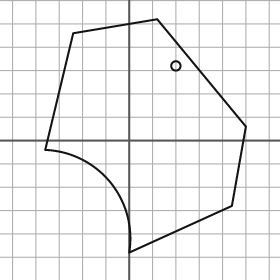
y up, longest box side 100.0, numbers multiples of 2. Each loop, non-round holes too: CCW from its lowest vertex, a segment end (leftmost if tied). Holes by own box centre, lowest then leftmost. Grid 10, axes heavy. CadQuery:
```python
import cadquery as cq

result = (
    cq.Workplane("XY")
    .moveTo(0.0, -48.0)
    .lineTo(44.0, -28.0)
    .lineTo(50.0, 6.0)
    .lineTo(12.0, 52.0)
    .lineTo(-24.0, 46.0)
    .lineTo(-36.0, -4.0)
    .threePointArc((-8.0, -18.0), (0.0, -48.0))
    .close()
    .moveTo(20.0, 32.0)
    .circle(2.0)
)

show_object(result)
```